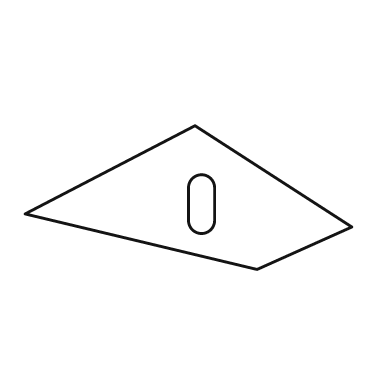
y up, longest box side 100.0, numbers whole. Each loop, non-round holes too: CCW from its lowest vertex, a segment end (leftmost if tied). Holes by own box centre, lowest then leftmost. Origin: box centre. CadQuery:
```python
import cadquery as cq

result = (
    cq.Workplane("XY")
    .moveTo(21.0, -22.0)
    .lineTo(50.0, -9.0)
    .lineTo(2.0, 22.0)
    .lineTo(-50.0, -5.0)
    .close()
    .moveTo(0.0, -7.0)
    .threePointArc((4.0, -11.0), (8.0, -7.0))
    .lineTo(8.0, 3.0)
    .threePointArc((4.0, 7.0), (0.0, 3.0))
    .close()
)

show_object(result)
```